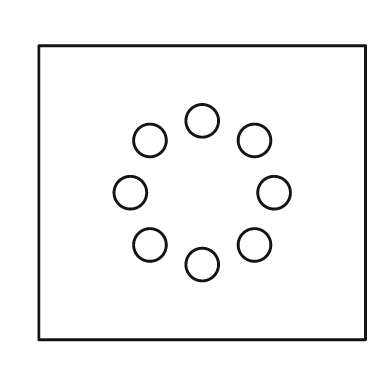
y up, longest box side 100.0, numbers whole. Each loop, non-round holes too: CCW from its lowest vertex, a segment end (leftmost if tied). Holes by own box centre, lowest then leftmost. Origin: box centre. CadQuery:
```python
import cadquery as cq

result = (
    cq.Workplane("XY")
    .moveTo(-50.0, -45.0)
    .lineTo(50.0, -45.0)
    .lineTo(50.0, 45.0)
    .lineTo(-50.0, 45.0)
    .close()
    .moveTo(0.0, -22.0)
    .circle(5.0)
    .moveTo(-16.0, -16.0)
    .circle(5.0)
    .moveTo(16.0, -16.0)
    .circle(5.0)
    .moveTo(-22.0, 0.0)
    .circle(5.0)
    .moveTo(22.0, 0.0)
    .circle(5.0)
    .moveTo(-16.0, 16.0)
    .circle(5.0)
    .moveTo(16.0, 16.0)
    .circle(5.0)
    .moveTo(0.0, 22.0)
    .circle(5.0)
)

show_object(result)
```